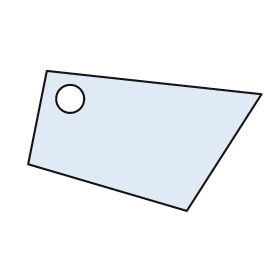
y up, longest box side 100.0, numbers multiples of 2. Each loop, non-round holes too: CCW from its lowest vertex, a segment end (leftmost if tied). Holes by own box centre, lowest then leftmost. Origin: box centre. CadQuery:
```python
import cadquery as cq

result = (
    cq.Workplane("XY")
    .moveTo(18.0, -30.0)
    .lineTo(50.0, 20.0)
    .lineTo(-42.0, 30.0)
    .lineTo(-50.0, -10.0)
    .close()
    .moveTo(-32.0, 18.0)
    .circle(6.0)
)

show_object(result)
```